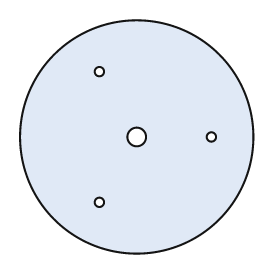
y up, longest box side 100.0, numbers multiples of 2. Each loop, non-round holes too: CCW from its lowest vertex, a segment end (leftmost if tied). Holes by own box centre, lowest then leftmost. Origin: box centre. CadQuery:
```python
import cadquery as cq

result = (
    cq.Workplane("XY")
    .moveTo(0.0, 0.0)
    .circle(50.0)
    .moveTo(-16.0, -28.0)
    .circle(2.0)
    .moveTo(0.0, 0.0)
    .circle(4.0)
    .moveTo(32.0, 0.0)
    .circle(2.0)
    .moveTo(-16.0, 28.0)
    .circle(2.0)
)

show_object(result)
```